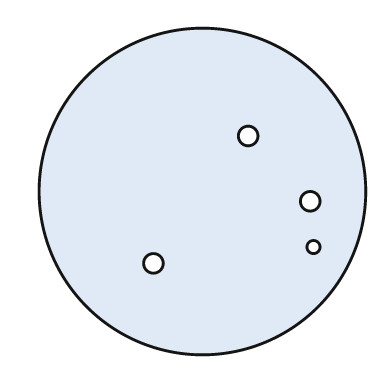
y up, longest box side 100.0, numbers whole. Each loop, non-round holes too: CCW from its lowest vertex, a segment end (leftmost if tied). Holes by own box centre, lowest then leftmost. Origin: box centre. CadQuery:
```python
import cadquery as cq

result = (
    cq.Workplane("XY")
    .moveTo(0.0, 0.0)
    .circle(50.0)
    .moveTo(-15.0, -22.0)
    .circle(3.0)
    .moveTo(34.0, -17.0)
    .circle(2.0)
    .moveTo(33.0, -3.0)
    .circle(3.0)
    .moveTo(14.0, 17.0)
    .circle(3.0)
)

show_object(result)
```